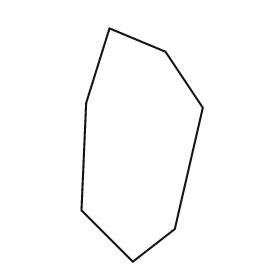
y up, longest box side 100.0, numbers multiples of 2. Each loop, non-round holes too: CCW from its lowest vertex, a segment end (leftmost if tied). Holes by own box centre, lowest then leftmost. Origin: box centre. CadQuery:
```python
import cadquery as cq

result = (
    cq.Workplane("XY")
    .moveTo(-4.0, -50.0)
    .lineTo(14.0, -36.0)
    .lineTo(26.0, 16.0)
    .lineTo(10.0, 40.0)
    .lineTo(-14.0, 50.0)
    .lineTo(-24.0, 18.0)
    .lineTo(-26.0, -28.0)
    .close()
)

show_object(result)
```